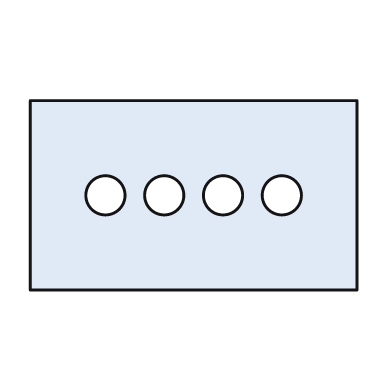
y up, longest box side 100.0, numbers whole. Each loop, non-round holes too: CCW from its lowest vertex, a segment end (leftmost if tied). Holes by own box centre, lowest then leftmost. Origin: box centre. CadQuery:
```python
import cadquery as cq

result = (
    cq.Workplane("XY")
    .moveTo(-50.0, -29.0)
    .lineTo(50.0, -29.0)
    .lineTo(50.0, 29.0)
    .lineTo(-50.0, 29.0)
    .close()
    .moveTo(-27.0, 0.0)
    .circle(6.0)
    .moveTo(-9.0, 0.0)
    .circle(6.0)
    .moveTo(9.0, 0.0)
    .circle(6.0)
    .moveTo(27.0, 0.0)
    .circle(6.0)
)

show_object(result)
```